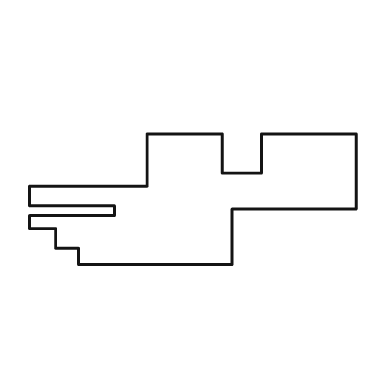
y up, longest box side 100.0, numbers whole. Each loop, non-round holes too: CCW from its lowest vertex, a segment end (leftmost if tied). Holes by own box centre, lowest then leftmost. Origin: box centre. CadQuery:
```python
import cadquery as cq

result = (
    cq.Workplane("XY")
    .moveTo(-35.0, -20.0)
    .lineTo(12.0, -20.0)
    .lineTo(12.0, -3.0)
    .lineTo(50.0, -3.0)
    .lineTo(50.0, 20.0)
    .lineTo(21.0, 20.0)
    .lineTo(21.0, 8.0)
    .lineTo(9.0, 8.0)
    .lineTo(9.0, 20.0)
    .lineTo(-14.0, 20.0)
    .lineTo(-14.0, 4.0)
    .lineTo(-50.0, 4.0)
    .lineTo(-50.0, -2.0)
    .lineTo(-24.0, -2.0)
    .lineTo(-24.0, -5.0)
    .lineTo(-50.0, -5.0)
    .lineTo(-50.0, -9.0)
    .lineTo(-42.0, -9.0)
    .lineTo(-42.0, -15.0)
    .lineTo(-35.0, -15.0)
    .close()
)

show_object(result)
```